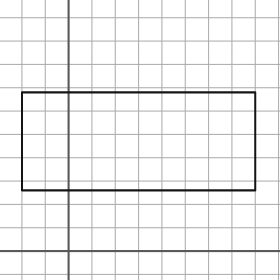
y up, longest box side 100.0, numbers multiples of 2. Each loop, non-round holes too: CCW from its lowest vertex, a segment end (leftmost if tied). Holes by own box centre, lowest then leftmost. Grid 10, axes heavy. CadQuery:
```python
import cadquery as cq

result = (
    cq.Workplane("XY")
    .moveTo(-20.0, 26.0)
    .lineTo(80.0, 26.0)
    .lineTo(80.0, 68.0)
    .lineTo(-20.0, 68.0)
    .close()
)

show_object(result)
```